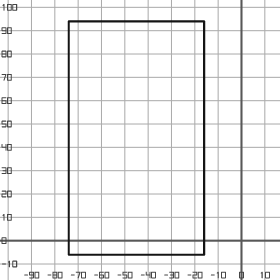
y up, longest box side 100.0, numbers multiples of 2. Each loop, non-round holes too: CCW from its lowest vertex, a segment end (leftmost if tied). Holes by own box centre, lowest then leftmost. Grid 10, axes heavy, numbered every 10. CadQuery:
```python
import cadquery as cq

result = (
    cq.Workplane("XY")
    .moveTo(-74.0, -6.0)
    .lineTo(-16.0, -6.0)
    .lineTo(-16.0, 94.0)
    .lineTo(-74.0, 94.0)
    .close()
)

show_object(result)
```